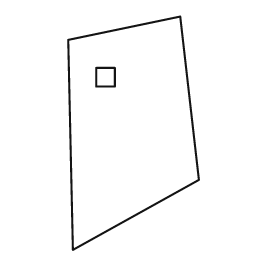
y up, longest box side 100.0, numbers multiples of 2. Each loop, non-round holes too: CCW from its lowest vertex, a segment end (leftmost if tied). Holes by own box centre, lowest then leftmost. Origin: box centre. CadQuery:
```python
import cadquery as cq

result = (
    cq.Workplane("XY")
    .moveTo(-26.0, -50.0)
    .lineTo(28.0, -20.0)
    .lineTo(20.0, 50.0)
    .lineTo(-28.0, 40.0)
    .close()
    .moveTo(-16.0, 20.0)
    .lineTo(-8.0, 20.0)
    .lineTo(-8.0, 28.0)
    .lineTo(-16.0, 28.0)
    .close()
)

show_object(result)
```